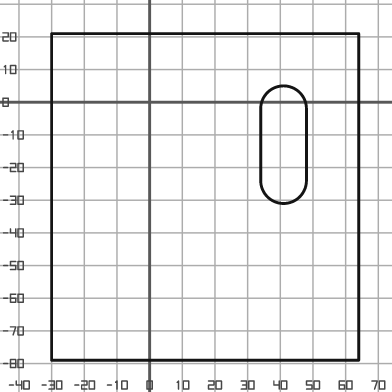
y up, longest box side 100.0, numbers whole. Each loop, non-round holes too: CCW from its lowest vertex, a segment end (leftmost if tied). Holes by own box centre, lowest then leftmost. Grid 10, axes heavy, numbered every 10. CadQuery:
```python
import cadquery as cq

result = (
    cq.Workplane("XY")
    .moveTo(-30.0, -79.0)
    .lineTo(64.0, -79.0)
    .lineTo(64.0, 21.0)
    .lineTo(-30.0, 21.0)
    .close()
    .moveTo(34.0, -24.0)
    .threePointArc((41.0, -31.0), (48.0, -24.0))
    .lineTo(48.0, -2.0)
    .threePointArc((41.0, 5.0), (34.0, -2.0))
    .close()
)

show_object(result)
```